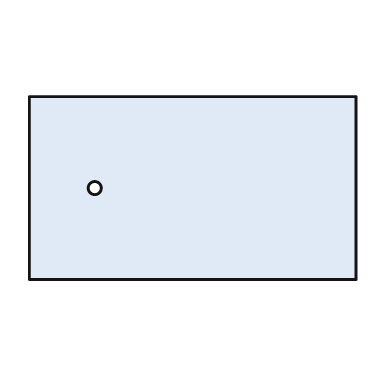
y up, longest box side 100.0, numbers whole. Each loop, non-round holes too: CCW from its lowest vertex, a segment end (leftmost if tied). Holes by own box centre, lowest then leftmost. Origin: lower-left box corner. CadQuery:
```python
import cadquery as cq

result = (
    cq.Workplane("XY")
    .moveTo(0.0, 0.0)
    .lineTo(100.0, 0.0)
    .lineTo(100.0, 56.0)
    .lineTo(0.0, 56.0)
    .close()
    .moveTo(20.0, 28.0)
    .circle(2.0)
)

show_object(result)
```